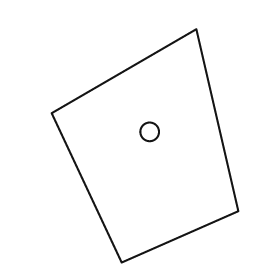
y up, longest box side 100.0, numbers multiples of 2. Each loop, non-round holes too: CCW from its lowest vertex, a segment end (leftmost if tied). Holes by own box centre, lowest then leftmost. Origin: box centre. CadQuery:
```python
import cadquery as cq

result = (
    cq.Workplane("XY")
    .moveTo(-10.0, -50.0)
    .lineTo(40.0, -28.0)
    .lineTo(22.0, 50.0)
    .lineTo(-40.0, 14.0)
    .close()
    .moveTo(2.0, 6.0)
    .circle(4.0)
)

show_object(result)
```